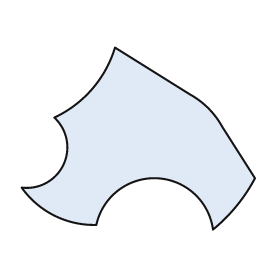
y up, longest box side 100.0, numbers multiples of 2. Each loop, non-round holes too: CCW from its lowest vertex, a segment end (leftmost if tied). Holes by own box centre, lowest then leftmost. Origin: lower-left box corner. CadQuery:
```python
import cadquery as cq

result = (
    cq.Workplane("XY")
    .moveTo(82.0, 0.0)
    .threePointArc((92.0, 10.0), (100.0, 22.0))
    .lineTo(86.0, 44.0)
    .threePointArc((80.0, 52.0), (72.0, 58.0))
    .lineTo(40.0, 78.0)
    .threePointArc((30.0, 60.0), (14.0, 48.0))
    .threePointArc((18.0, 28.0), (0.0, 18.0))
    .threePointArc((14.0, 6.0), (32.0, 2.0))
    .threePointArc((58.0, 22.0), (82.0, 0.0))
    .close()
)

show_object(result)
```